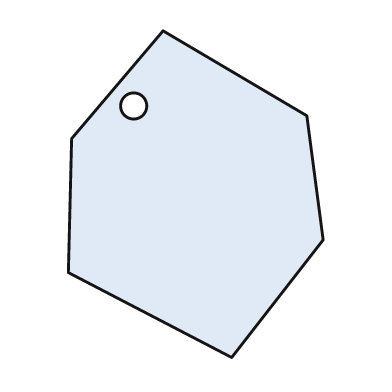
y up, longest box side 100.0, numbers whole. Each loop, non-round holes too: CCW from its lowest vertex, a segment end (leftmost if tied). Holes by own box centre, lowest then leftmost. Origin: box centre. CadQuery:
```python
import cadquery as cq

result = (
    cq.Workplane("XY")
    .moveTo(11.0, -50.0)
    .lineTo(39.0, -14.0)
    .lineTo(34.0, 24.0)
    .lineTo(-10.0, 50.0)
    .lineTo(-38.0, 17.0)
    .lineTo(-39.0, -24.0)
    .close()
    .moveTo(-19.0, 27.0)
    .circle(4.0)
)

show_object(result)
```